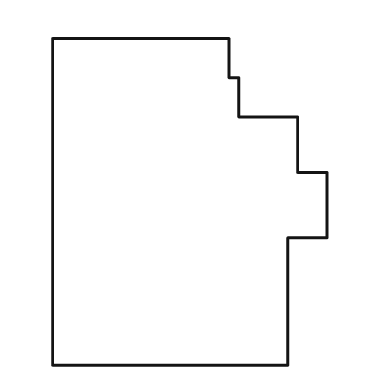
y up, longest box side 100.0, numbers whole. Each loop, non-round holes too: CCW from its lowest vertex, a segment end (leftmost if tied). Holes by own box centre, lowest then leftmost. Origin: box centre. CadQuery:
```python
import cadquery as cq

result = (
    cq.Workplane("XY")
    .moveTo(-42.0, -50.0)
    .lineTo(30.0, -50.0)
    .lineTo(30.0, -11.0)
    .lineTo(42.0, -11.0)
    .lineTo(42.0, 9.0)
    .lineTo(33.0, 9.0)
    .lineTo(33.0, 26.0)
    .lineTo(15.0, 26.0)
    .lineTo(15.0, 38.0)
    .lineTo(12.0, 38.0)
    .lineTo(12.0, 50.0)
    .lineTo(-42.0, 50.0)
    .close()
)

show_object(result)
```